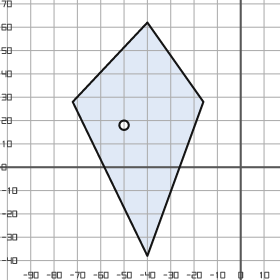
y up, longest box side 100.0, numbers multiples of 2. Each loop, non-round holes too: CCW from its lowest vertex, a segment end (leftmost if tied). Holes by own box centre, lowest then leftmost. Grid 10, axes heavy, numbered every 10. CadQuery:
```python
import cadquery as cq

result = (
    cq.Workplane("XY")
    .moveTo(-40.0, -38.0)
    .lineTo(-16.0, 28.0)
    .lineTo(-40.0, 62.0)
    .lineTo(-72.0, 28.0)
    .close()
    .moveTo(-50.0, 18.0)
    .circle(2.0)
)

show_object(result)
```